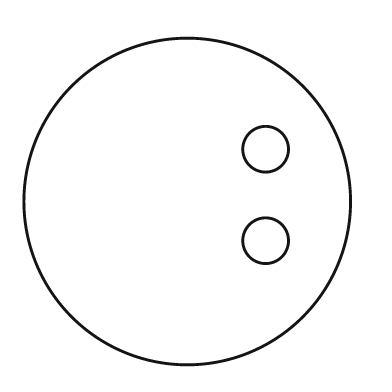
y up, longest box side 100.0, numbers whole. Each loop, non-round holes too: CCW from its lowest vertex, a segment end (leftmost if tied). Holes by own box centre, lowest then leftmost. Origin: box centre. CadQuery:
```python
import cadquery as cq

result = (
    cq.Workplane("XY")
    .moveTo(0.0, 0.0)
    .circle(50.0)
    .moveTo(24.0, -12.0)
    .circle(7.0)
    .moveTo(24.0, 16.0)
    .circle(7.0)
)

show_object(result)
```